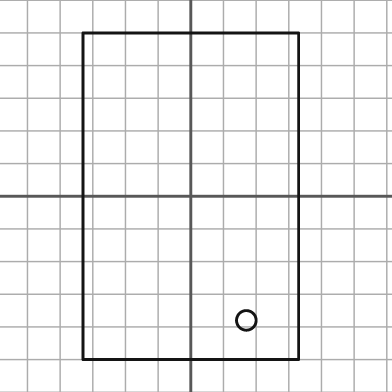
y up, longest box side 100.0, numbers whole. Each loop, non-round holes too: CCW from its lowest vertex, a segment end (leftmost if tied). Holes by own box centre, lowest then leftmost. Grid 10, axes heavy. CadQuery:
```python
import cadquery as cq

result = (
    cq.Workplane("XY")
    .moveTo(-33.0, -50.0)
    .lineTo(33.0, -50.0)
    .lineTo(33.0, 50.0)
    .lineTo(-33.0, 50.0)
    .close()
    .moveTo(17.0, -38.0)
    .circle(3.0)
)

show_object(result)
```